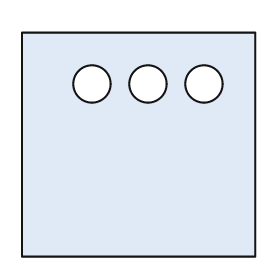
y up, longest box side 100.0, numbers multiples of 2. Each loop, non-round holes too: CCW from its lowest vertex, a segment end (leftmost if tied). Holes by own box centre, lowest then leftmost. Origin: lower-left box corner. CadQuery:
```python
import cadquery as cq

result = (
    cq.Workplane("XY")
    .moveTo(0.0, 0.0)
    .lineTo(100.0, 0.0)
    .lineTo(100.0, 96.0)
    .lineTo(0.0, 96.0)
    .close()
    .moveTo(30.0, 74.0)
    .circle(8.0)
    .moveTo(54.0, 74.0)
    .circle(8.0)
    .moveTo(78.0, 74.0)
    .circle(8.0)
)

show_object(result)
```